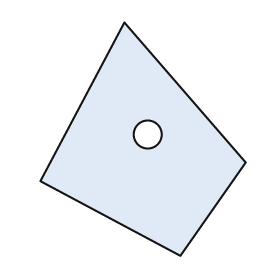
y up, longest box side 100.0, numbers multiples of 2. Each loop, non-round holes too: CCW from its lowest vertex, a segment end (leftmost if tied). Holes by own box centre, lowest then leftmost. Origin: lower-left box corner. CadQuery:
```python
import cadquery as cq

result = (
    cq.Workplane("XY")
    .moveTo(60.0, 0.0)
    .lineTo(88.0, 40.0)
    .lineTo(36.0, 100.0)
    .lineTo(0.0, 32.0)
    .close()
    .moveTo(46.0, 52.0)
    .circle(6.0)
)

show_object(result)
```